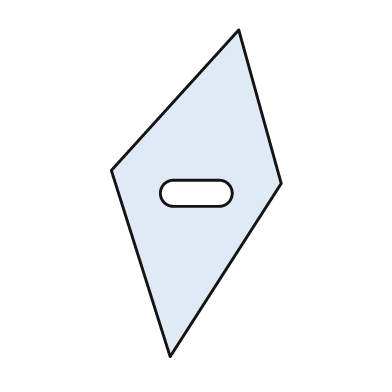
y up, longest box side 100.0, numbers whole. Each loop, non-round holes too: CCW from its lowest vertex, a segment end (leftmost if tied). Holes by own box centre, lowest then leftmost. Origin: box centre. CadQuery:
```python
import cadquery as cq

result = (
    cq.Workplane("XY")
    .moveTo(-8.0, -50.0)
    .lineTo(26.0, 3.0)
    .lineTo(13.0, 50.0)
    .lineTo(-26.0, 7.0)
    .close()
    .moveTo(-7.0, -4.0)
    .lineTo(7.0, -4.0)
    .threePointArc((11.0, 0.0), (7.0, 4.0))
    .lineTo(-7.0, 4.0)
    .threePointArc((-11.0, 0.0), (-7.0, -4.0))
    .close()
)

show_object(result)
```